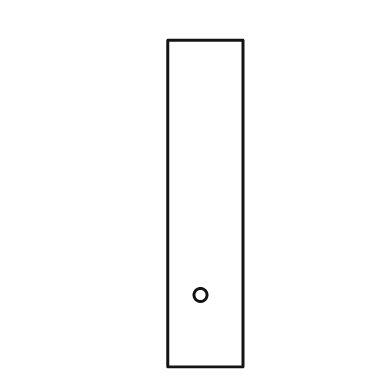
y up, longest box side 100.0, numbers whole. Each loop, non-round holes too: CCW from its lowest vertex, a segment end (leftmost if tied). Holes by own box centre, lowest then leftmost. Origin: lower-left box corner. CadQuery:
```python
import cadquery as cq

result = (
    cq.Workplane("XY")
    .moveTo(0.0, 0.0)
    .lineTo(23.0, 0.0)
    .lineTo(23.0, 100.0)
    .lineTo(0.0, 100.0)
    .close()
    .moveTo(10.0, 22.0)
    .circle(2.0)
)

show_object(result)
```